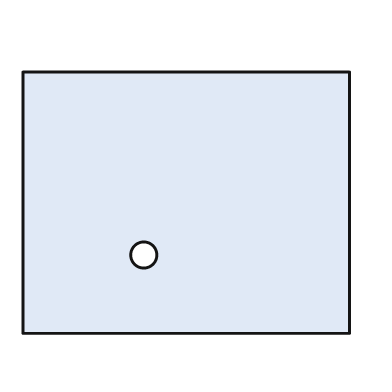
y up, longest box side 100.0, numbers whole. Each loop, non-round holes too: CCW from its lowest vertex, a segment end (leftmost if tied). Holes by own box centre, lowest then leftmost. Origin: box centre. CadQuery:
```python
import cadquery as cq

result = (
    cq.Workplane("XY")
    .moveTo(-50.0, -40.0)
    .lineTo(50.0, -40.0)
    .lineTo(50.0, 40.0)
    .lineTo(-50.0, 40.0)
    .close()
    .moveTo(-13.0, -16.0)
    .circle(4.0)
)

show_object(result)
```